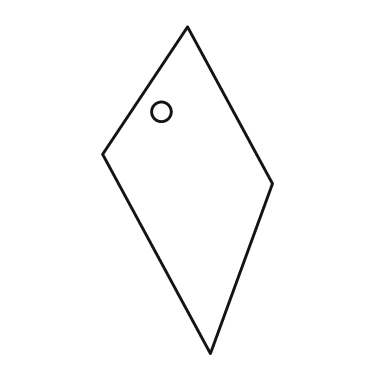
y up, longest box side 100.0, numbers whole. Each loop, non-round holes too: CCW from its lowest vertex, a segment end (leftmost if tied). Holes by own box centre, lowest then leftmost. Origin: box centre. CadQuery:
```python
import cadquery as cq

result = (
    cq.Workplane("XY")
    .moveTo(7.0, -50.0)
    .lineTo(26.0, 2.0)
    .lineTo(0.0, 50.0)
    .lineTo(-26.0, 11.0)
    .close()
    .moveTo(-8.0, 24.0)
    .circle(3.0)
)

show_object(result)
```